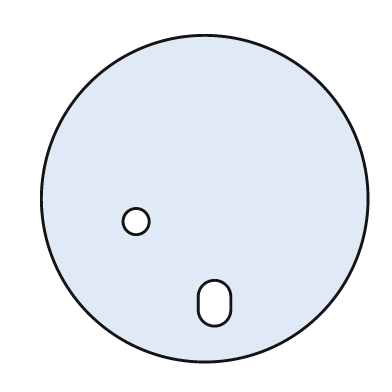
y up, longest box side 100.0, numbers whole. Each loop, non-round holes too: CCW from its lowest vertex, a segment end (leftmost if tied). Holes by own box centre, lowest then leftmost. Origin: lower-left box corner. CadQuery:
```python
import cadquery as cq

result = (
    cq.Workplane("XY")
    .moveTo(50.0, 50.0)
    .circle(50.0)
    .moveTo(48.0, 16.0)
    .threePointArc((53.0, 11.0), (58.0, 16.0))
    .lineTo(58.0, 20.0)
    .threePointArc((53.0, 25.0), (48.0, 20.0))
    .close()
    .moveTo(29.0, 43.0)
    .circle(4.0)
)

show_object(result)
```